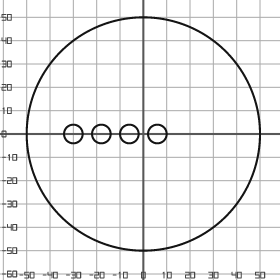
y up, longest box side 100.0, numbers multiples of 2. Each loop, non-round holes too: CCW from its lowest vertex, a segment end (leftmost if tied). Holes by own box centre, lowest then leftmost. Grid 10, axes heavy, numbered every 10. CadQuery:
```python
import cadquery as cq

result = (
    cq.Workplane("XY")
    .moveTo(0.0, 0.0)
    .circle(50.0)
    .moveTo(-30.0, 0.0)
    .circle(4.0)
    .moveTo(-18.0, 0.0)
    .circle(4.0)
    .moveTo(-6.0, 0.0)
    .circle(4.0)
    .moveTo(6.0, 0.0)
    .circle(4.0)
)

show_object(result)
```